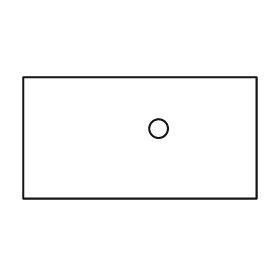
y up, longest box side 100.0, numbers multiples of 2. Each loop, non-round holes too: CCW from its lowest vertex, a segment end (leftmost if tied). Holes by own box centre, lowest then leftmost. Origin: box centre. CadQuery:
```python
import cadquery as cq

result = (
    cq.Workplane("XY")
    .moveTo(-50.0, -26.0)
    .lineTo(50.0, -26.0)
    .lineTo(50.0, 26.0)
    .lineTo(-50.0, 26.0)
    .close()
    .moveTo(8.0, 4.0)
    .circle(4.0)
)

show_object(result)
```